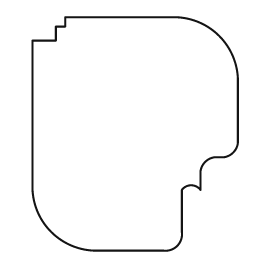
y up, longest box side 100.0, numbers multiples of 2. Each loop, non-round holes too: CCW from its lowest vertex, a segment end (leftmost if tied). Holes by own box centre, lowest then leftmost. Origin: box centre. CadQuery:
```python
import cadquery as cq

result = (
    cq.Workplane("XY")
    .moveTo(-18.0, -50.0)
    .lineTo(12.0, -50.0)
    .threePointArc((18.0, -48.0), (20.0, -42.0))
    .lineTo(20.0, -24.0)
    .threePointArc((24.0, -22.0), (28.0, -24.0))
    .lineTo(28.0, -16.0)
    .threePointArc((30.0, -12.0), (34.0, -10.0))
    .lineTo(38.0, -10.0)
    .threePointArc((42.0, -8.0), (44.0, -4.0))
    .lineTo(44.0, 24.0)
    .threePointArc((36.0, 42.0), (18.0, 50.0))
    .lineTo(-30.0, 50.0)
    .lineTo(-30.0, 46.0)
    .lineTo(-34.0, 46.0)
    .lineTo(-34.0, 40.0)
    .lineTo(-44.0, 40.0)
    .lineTo(-44.0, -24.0)
    .threePointArc((-36.0, -42.0), (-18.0, -50.0))
    .close()
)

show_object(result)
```